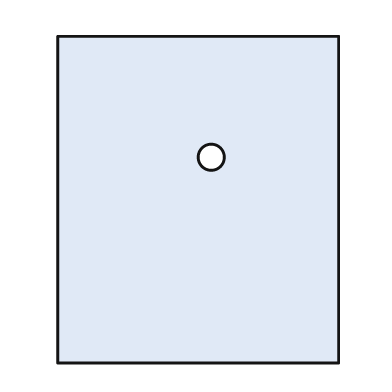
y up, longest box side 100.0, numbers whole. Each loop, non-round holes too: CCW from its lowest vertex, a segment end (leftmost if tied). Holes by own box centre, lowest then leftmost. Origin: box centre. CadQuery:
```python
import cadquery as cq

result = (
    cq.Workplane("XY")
    .moveTo(-43.0, -50.0)
    .lineTo(43.0, -50.0)
    .lineTo(43.0, 50.0)
    .lineTo(-43.0, 50.0)
    .close()
    .moveTo(4.0, 13.0)
    .circle(4.0)
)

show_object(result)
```